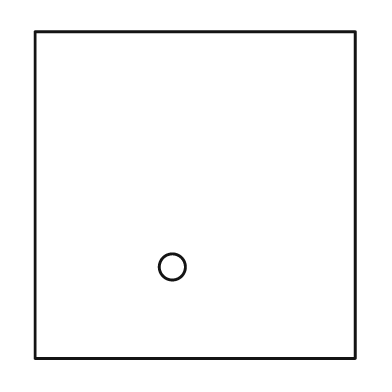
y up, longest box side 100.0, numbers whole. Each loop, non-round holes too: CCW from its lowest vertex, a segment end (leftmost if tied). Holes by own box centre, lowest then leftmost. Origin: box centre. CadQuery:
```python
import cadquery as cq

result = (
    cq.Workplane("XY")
    .moveTo(-49.0, -50.0)
    .lineTo(49.0, -50.0)
    .lineTo(49.0, 50.0)
    .lineTo(-49.0, 50.0)
    .close()
    .moveTo(-7.0, -22.0)
    .circle(4.0)
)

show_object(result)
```